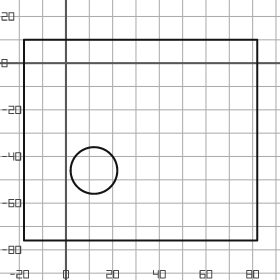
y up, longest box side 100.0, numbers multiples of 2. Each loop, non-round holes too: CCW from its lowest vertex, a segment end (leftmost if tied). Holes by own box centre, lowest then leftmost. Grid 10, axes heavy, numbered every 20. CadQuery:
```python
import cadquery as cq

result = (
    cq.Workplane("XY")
    .moveTo(-18.0, -76.0)
    .lineTo(82.0, -76.0)
    .lineTo(82.0, 10.0)
    .lineTo(-18.0, 10.0)
    .close()
    .moveTo(12.0, -46.0)
    .circle(10.0)
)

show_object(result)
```